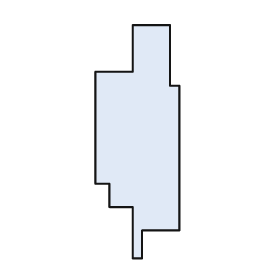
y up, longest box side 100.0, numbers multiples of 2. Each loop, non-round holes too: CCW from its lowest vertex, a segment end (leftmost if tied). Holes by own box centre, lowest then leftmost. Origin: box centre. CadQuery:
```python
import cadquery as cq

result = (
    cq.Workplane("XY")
    .moveTo(-2.0, -50.0)
    .lineTo(2.0, -50.0)
    .lineTo(2.0, -38.0)
    .lineTo(18.0, -38.0)
    .lineTo(18.0, 24.0)
    .lineTo(14.0, 24.0)
    .lineTo(14.0, 50.0)
    .lineTo(-2.0, 50.0)
    .lineTo(-2.0, 30.0)
    .lineTo(-18.0, 30.0)
    .lineTo(-18.0, -18.0)
    .lineTo(-12.0, -18.0)
    .lineTo(-12.0, -28.0)
    .lineTo(-2.0, -28.0)
    .close()
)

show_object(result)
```